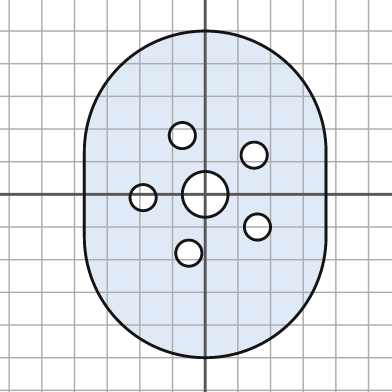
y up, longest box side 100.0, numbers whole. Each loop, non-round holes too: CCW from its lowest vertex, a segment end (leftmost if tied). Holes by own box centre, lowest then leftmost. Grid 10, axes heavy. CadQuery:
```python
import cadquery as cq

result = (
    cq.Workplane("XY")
    .moveTo(-37.0, -13.0)
    .threePointArc((0.0, -50.0), (37.0, -13.0))
    .lineTo(37.0, 13.0)
    .threePointArc((0.0, 50.0), (-37.0, 13.0))
    .close()
    .moveTo(-5.0, -18.0)
    .circle(4.0)
    .moveTo(16.0, -10.0)
    .circle(4.0)
    .moveTo(-19.0, -1.0)
    .circle(4.0)
    .moveTo(0.0, 0.0)
    .circle(7.0)
    .moveTo(15.0, 12.0)
    .circle(4.0)
    .moveTo(-7.0, 18.0)
    .circle(4.0)
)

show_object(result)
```